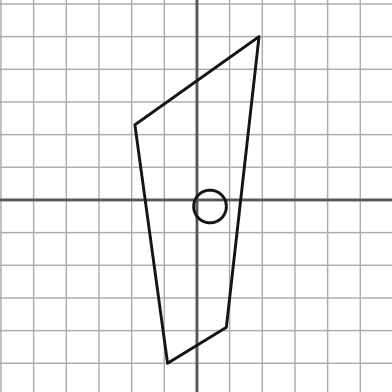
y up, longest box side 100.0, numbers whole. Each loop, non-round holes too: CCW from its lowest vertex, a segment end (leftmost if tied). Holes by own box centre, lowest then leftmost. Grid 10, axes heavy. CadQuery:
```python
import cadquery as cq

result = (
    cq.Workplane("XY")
    .moveTo(-9.0, -50.0)
    .lineTo(9.0, -39.0)
    .lineTo(19.0, 50.0)
    .lineTo(-19.0, 23.0)
    .close()
    .moveTo(4.0, -2.0)
    .circle(5.0)
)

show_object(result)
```